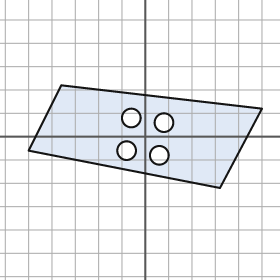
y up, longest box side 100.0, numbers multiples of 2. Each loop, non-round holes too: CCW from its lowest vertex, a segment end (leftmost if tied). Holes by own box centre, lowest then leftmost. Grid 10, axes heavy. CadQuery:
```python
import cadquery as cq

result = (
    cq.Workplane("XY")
    .moveTo(32.0, -22.0)
    .lineTo(50.0, 12.0)
    .lineTo(-36.0, 22.0)
    .lineTo(-50.0, -6.0)
    .close()
    .moveTo(6.0, -8.0)
    .circle(4.0)
    .moveTo(-8.0, -6.0)
    .circle(4.0)
    .moveTo(8.0, 6.0)
    .circle(4.0)
    .moveTo(-6.0, 8.0)
    .circle(4.0)
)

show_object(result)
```